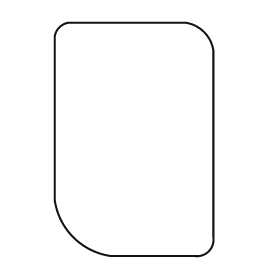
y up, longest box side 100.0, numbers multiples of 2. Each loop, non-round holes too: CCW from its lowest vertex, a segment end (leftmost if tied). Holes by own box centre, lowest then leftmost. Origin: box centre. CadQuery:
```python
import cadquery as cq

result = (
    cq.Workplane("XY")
    .moveTo(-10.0, -50.0)
    .lineTo(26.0, -50.0)
    .threePointArc((32.0, -48.0), (34.0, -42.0))
    .lineTo(34.0, 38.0)
    .threePointArc((30.0, 46.0), (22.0, 50.0))
    .lineTo(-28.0, 50.0)
    .threePointArc((-32.0, 48.0), (-34.0, 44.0))
    .lineTo(-34.0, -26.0)
    .threePointArc((-26.0, -42.0), (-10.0, -50.0))
    .close()
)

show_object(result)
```